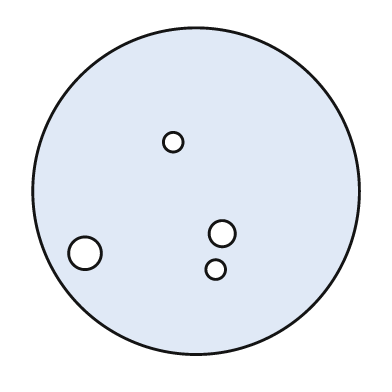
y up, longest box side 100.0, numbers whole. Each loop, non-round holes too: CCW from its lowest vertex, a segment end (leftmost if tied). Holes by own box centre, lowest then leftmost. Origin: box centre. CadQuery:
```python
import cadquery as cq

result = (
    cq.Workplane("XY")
    .moveTo(0.0, 0.0)
    .circle(50.0)
    .moveTo(6.0, -24.0)
    .circle(3.0)
    .moveTo(-34.0, -19.0)
    .circle(5.0)
    .moveTo(8.0, -13.0)
    .circle(4.0)
    .moveTo(-7.0, 15.0)
    .circle(3.0)
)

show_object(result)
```